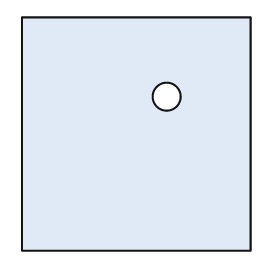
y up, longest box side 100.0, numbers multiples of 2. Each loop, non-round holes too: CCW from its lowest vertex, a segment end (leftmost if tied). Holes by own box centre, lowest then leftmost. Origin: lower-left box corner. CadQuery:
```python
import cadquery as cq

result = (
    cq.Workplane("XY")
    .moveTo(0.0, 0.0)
    .lineTo(98.0, 0.0)
    .lineTo(98.0, 100.0)
    .lineTo(0.0, 100.0)
    .close()
    .moveTo(62.0, 66.0)
    .circle(6.0)
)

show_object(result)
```